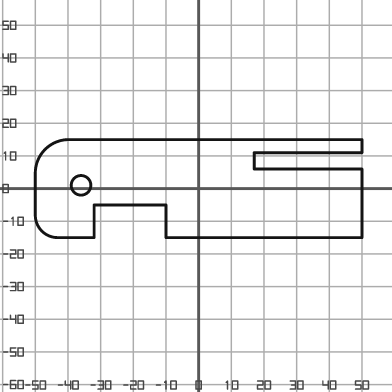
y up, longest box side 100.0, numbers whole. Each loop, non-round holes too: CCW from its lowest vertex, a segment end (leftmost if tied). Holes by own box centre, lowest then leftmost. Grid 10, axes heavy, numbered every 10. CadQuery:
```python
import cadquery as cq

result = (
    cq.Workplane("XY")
    .moveTo(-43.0, -15.0)
    .lineTo(-32.0, -15.0)
    .lineTo(-32.0, -5.0)
    .lineTo(-10.0, -5.0)
    .lineTo(-10.0, -15.0)
    .lineTo(50.0, -15.0)
    .lineTo(50.0, 6.0)
    .lineTo(17.0, 6.0)
    .lineTo(17.0, 11.0)
    .lineTo(50.0, 11.0)
    .lineTo(50.0, 15.0)
    .lineTo(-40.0, 15.0)
    .threePointArc((-47.0, 12.0), (-50.0, 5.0))
    .lineTo(-50.0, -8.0)
    .threePointArc((-48.0, -13.0), (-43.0, -15.0))
    .close()
    .moveTo(-36.0, 1.0)
    .circle(3.0)
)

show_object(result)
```